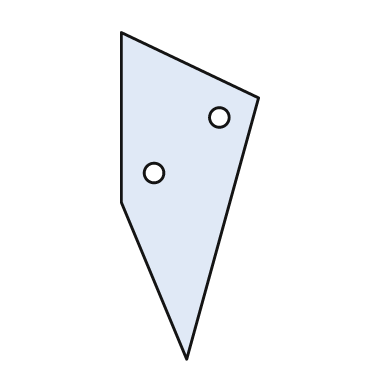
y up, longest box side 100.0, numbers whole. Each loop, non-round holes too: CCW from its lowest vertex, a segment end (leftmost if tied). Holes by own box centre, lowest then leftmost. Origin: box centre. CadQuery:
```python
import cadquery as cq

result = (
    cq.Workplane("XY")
    .moveTo(-1.0, -50.0)
    .lineTo(21.0, 30.0)
    .lineTo(-21.0, 50.0)
    .lineTo(-21.0, -2.0)
    .close()
    .moveTo(-11.0, 7.0)
    .circle(3.0)
    .moveTo(9.0, 24.0)
    .circle(3.0)
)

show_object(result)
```